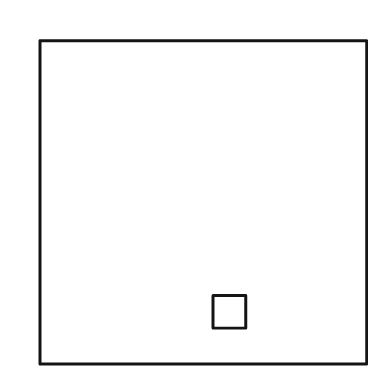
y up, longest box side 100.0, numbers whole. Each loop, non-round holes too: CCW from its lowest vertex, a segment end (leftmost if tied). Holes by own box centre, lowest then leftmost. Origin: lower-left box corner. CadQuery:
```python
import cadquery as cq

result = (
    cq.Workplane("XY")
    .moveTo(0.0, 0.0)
    .lineTo(100.0, 0.0)
    .lineTo(100.0, 99.0)
    .lineTo(0.0, 99.0)
    .close()
    .moveTo(53.0, 11.0)
    .lineTo(63.0, 11.0)
    .lineTo(63.0, 21.0)
    .lineTo(53.0, 21.0)
    .close()
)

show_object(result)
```